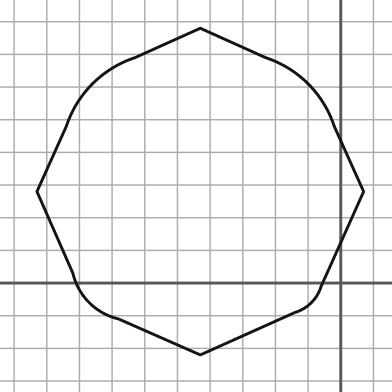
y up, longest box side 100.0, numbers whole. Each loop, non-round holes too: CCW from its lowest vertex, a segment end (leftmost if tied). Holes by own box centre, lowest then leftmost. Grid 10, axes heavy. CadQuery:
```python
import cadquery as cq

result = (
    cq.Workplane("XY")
    .moveTo(-43.0, -22.0)
    .lineTo(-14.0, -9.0)
    .threePointArc((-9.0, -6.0), (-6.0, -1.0))
    .lineTo(7.0, 28.0)
    .lineTo(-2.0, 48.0)
    .threePointArc((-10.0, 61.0), (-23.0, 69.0))
    .lineTo(-43.0, 78.0)
    .lineTo(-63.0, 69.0)
    .threePointArc((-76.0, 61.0), (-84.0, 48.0))
    .lineTo(-93.0, 28.0)
    .lineTo(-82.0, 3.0)
    .threePointArc((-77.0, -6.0), (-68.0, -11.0))
    .close()
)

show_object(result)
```